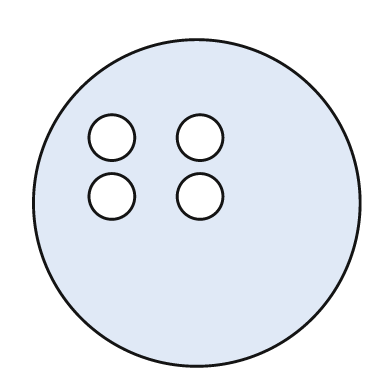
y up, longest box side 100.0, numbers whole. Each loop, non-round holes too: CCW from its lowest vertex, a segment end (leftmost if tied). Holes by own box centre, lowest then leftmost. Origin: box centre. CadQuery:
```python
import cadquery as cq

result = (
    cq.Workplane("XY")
    .moveTo(0.0, 0.0)
    .circle(50.0)
    .moveTo(-26.0, 2.0)
    .circle(7.0)
    .moveTo(1.0, 2.0)
    .circle(7.0)
    .moveTo(-26.0, 20.0)
    .circle(7.0)
    .moveTo(1.0, 20.0)
    .circle(7.0)
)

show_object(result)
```